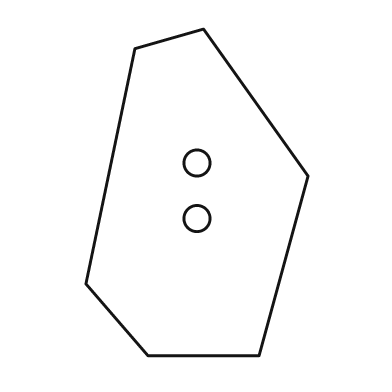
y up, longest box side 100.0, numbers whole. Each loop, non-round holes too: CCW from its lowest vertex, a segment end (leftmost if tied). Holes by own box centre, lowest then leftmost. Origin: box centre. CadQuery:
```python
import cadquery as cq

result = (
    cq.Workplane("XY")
    .moveTo(-15.0, -50.0)
    .lineTo(19.0, -50.0)
    .lineTo(34.0, 5.0)
    .lineTo(2.0, 50.0)
    .lineTo(-19.0, 44.0)
    .lineTo(-34.0, -28.0)
    .close()
    .moveTo(0.0, -8.0)
    .circle(4.0)
    .moveTo(0.0, 9.0)
    .circle(4.0)
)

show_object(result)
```